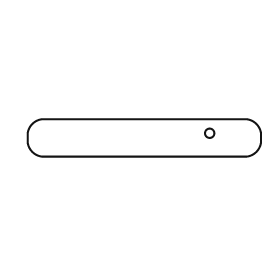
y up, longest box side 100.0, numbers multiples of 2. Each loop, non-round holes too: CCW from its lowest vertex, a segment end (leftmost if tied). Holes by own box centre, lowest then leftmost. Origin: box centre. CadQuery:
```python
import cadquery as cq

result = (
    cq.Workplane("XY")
    .moveTo(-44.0, -8.0)
    .lineTo(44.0, -8.0)
    .threePointArc((48.0, -6.0), (50.0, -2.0))
    .lineTo(50.0, 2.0)
    .threePointArc((48.0, 6.0), (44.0, 8.0))
    .lineTo(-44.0, 8.0)
    .threePointArc((-48.0, 6.0), (-50.0, 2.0))
    .lineTo(-50.0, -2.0)
    .threePointArc((-48.0, -6.0), (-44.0, -8.0))
    .close()
    .moveTo(28.0, 2.0)
    .circle(2.0)
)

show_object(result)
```